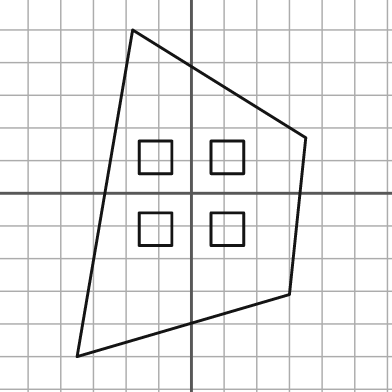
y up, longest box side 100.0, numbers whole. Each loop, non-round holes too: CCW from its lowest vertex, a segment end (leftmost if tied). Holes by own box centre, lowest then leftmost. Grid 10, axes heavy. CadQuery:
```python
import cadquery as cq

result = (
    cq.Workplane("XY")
    .moveTo(-35.0, -50.0)
    .lineTo(30.0, -31.0)
    .lineTo(35.0, 17.0)
    .lineTo(-18.0, 50.0)
    .close()
    .moveTo(-16.0, -16.0)
    .lineTo(-6.0, -16.0)
    .lineTo(-6.0, -6.0)
    .lineTo(-16.0, -6.0)
    .close()
    .moveTo(6.0, -16.0)
    .lineTo(16.0, -16.0)
    .lineTo(16.0, -6.0)
    .lineTo(6.0, -6.0)
    .close()
    .moveTo(-16.0, 6.0)
    .lineTo(-6.0, 6.0)
    .lineTo(-6.0, 16.0)
    .lineTo(-16.0, 16.0)
    .close()
    .moveTo(6.0, 6.0)
    .lineTo(16.0, 6.0)
    .lineTo(16.0, 16.0)
    .lineTo(6.0, 16.0)
    .close()
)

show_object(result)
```